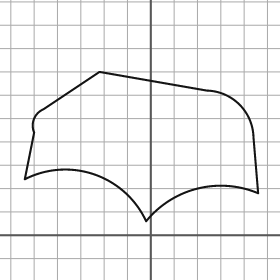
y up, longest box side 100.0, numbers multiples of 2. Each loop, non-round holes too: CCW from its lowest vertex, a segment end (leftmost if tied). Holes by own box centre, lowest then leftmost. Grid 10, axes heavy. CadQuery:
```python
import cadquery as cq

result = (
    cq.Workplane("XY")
    .moveTo(-2.0, 6.0)
    .threePointArc((20.0, 20.0), (46.0, 18.0))
    .lineTo(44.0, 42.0)
    .threePointArc((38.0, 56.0), (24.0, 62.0))
    .lineTo(-22.0, 70.0)
    .lineTo(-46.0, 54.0)
    .threePointArc((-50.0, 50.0), (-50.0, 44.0))
    .lineTo(-54.0, 24.0)
    .threePointArc((-24.0, 26.0), (-2.0, 6.0))
    .close()
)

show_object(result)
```